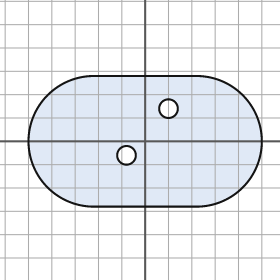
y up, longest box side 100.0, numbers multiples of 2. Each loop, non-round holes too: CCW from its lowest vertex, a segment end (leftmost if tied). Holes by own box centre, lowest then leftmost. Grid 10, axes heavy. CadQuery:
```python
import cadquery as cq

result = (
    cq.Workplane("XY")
    .moveTo(-22.0, -28.0)
    .lineTo(22.0, -28.0)
    .threePointArc((50.0, 0.0), (22.0, 28.0))
    .lineTo(-22.0, 28.0)
    .threePointArc((-50.0, 0.0), (-22.0, -28.0))
    .close()
    .moveTo(-8.0, -6.0)
    .circle(4.0)
    .moveTo(10.0, 14.0)
    .circle(4.0)
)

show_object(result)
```